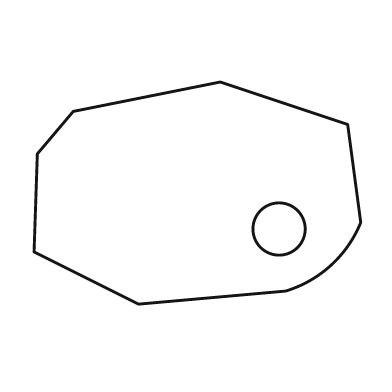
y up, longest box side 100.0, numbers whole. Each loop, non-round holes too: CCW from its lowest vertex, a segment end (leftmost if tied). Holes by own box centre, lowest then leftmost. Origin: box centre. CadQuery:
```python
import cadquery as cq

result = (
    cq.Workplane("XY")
    .moveTo(-18.0, -34.0)
    .lineTo(27.0, -30.0)
    .threePointArc((41.0, -22.0), (50.0, -9.0))
    .lineTo(46.0, 21.0)
    .lineTo(7.0, 34.0)
    .lineTo(-38.0, 25.0)
    .lineTo(-49.0, 12.0)
    .lineTo(-50.0, -18.0)
    .close()
    .moveTo(25.0, -11.0)
    .circle(8.0)
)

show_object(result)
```